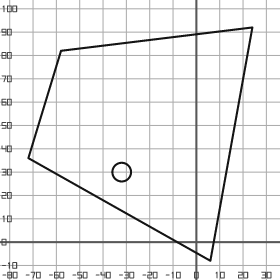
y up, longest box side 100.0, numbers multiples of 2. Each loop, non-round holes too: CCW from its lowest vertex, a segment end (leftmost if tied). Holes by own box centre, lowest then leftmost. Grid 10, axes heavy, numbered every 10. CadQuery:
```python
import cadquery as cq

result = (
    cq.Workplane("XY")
    .moveTo(6.0, -8.0)
    .lineTo(24.0, 92.0)
    .lineTo(-58.0, 82.0)
    .lineTo(-72.0, 36.0)
    .close()
    .moveTo(-32.0, 30.0)
    .circle(4.0)
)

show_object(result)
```